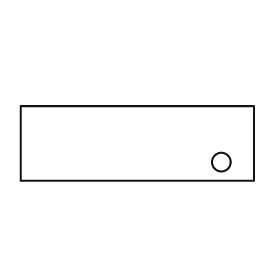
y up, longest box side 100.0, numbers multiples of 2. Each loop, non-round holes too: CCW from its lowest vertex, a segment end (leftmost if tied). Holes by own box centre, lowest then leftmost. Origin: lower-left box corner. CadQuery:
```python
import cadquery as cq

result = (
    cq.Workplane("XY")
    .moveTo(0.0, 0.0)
    .lineTo(100.0, 0.0)
    .lineTo(100.0, 32.0)
    .lineTo(0.0, 32.0)
    .close()
    .moveTo(86.0, 8.0)
    .circle(4.0)
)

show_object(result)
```